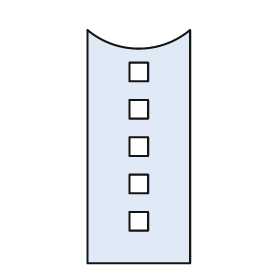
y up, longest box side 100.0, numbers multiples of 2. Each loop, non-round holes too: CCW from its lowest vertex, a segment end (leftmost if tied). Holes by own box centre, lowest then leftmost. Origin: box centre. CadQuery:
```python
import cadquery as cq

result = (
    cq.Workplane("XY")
    .moveTo(-22.0, -50.0)
    .lineTo(22.0, -50.0)
    .lineTo(22.0, 50.0)
    .threePointArc((0.0, 42.0), (-22.0, 50.0))
    .close()
    .moveTo(-4.0, -36.0)
    .lineTo(4.0, -36.0)
    .lineTo(4.0, -28.0)
    .lineTo(-4.0, -28.0)
    .close()
    .moveTo(-4.0, -20.0)
    .lineTo(4.0, -20.0)
    .lineTo(4.0, -12.0)
    .lineTo(-4.0, -12.0)
    .close()
    .moveTo(-4.0, -4.0)
    .lineTo(4.0, -4.0)
    .lineTo(4.0, 4.0)
    .lineTo(-4.0, 4.0)
    .close()
    .moveTo(-4.0, 12.0)
    .lineTo(4.0, 12.0)
    .lineTo(4.0, 20.0)
    .lineTo(-4.0, 20.0)
    .close()
    .moveTo(-4.0, 28.0)
    .lineTo(4.0, 28.0)
    .lineTo(4.0, 36.0)
    .lineTo(-4.0, 36.0)
    .close()
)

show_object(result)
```